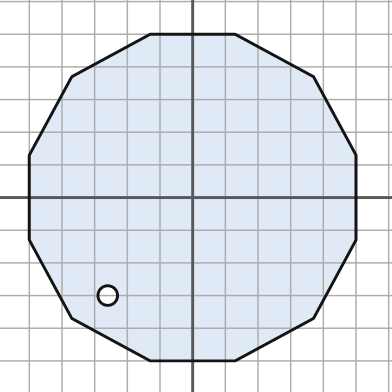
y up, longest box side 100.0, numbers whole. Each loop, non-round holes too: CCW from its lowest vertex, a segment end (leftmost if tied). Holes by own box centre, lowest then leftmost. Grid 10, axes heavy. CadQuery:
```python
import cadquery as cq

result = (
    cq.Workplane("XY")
    .moveTo(-13.0, -50.0)
    .lineTo(13.0, -50.0)
    .lineTo(37.0, -37.0)
    .lineTo(50.0, -13.0)
    .lineTo(50.0, 13.0)
    .lineTo(37.0, 37.0)
    .lineTo(13.0, 50.0)
    .lineTo(-13.0, 50.0)
    .lineTo(-37.0, 37.0)
    .lineTo(-50.0, 13.0)
    .lineTo(-50.0, -13.0)
    .lineTo(-37.0, -37.0)
    .close()
    .moveTo(-26.0, -30.0)
    .circle(3.0)
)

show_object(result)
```